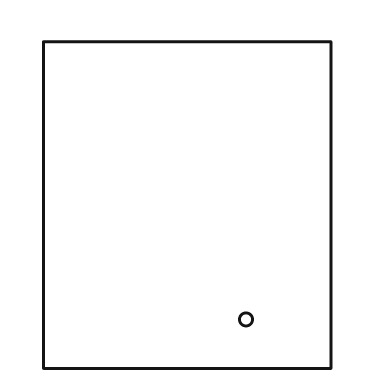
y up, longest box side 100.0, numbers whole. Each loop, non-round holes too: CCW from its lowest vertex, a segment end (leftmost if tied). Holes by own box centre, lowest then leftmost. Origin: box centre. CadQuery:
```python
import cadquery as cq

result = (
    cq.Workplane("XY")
    .moveTo(-44.0, -50.0)
    .lineTo(44.0, -50.0)
    .lineTo(44.0, 50.0)
    .lineTo(-44.0, 50.0)
    .close()
    .moveTo(18.0, -35.0)
    .circle(2.0)
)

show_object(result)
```